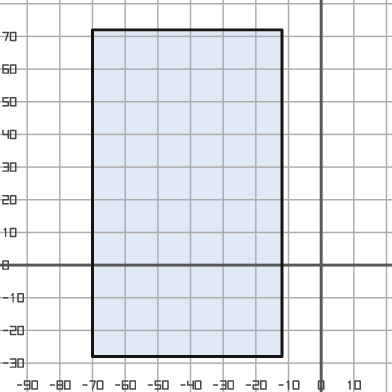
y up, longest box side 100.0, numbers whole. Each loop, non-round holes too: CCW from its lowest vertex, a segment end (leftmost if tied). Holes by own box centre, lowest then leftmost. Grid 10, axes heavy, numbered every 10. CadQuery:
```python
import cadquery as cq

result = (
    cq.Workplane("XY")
    .moveTo(-70.0, -28.0)
    .lineTo(-12.0, -28.0)
    .lineTo(-12.0, 72.0)
    .lineTo(-70.0, 72.0)
    .close()
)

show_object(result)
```